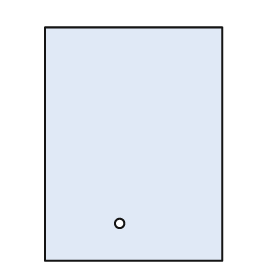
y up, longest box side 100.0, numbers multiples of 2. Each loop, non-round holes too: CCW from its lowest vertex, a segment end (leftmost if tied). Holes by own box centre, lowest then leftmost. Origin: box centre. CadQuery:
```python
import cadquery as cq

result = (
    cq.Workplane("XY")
    .moveTo(-38.0, -50.0)
    .lineTo(38.0, -50.0)
    .lineTo(38.0, 50.0)
    .lineTo(-38.0, 50.0)
    .close()
    .moveTo(-6.0, -34.0)
    .circle(2.0)
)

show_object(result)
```